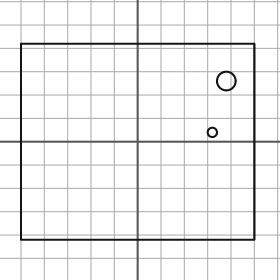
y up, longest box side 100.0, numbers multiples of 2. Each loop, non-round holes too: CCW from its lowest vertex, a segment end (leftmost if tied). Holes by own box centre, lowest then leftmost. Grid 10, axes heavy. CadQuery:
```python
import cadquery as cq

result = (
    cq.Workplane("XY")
    .moveTo(-50.0, -42.0)
    .lineTo(50.0, -42.0)
    .lineTo(50.0, 42.0)
    .lineTo(-50.0, 42.0)
    .close()
    .moveTo(32.0, 4.0)
    .circle(2.0)
    .moveTo(38.0, 26.0)
    .circle(4.0)
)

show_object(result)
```